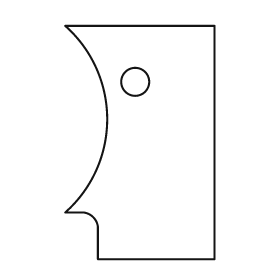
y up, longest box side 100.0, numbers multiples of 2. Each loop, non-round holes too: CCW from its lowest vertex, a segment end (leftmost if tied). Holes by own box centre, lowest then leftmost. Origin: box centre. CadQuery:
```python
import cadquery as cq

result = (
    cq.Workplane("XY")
    .moveTo(-18.0, -50.0)
    .lineTo(32.0, -50.0)
    .lineTo(32.0, 50.0)
    .lineTo(-32.0, 50.0)
    .threePointArc((-14.0, 10.0), (-32.0, -30.0))
    .lineTo(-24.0, -30.0)
    .threePointArc((-20.0, -32.0), (-18.0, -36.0))
    .close()
    .moveTo(-2.0, 26.0)
    .circle(6.0)
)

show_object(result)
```